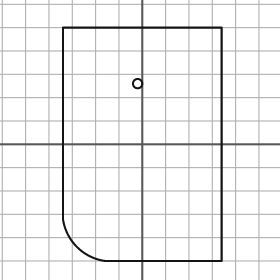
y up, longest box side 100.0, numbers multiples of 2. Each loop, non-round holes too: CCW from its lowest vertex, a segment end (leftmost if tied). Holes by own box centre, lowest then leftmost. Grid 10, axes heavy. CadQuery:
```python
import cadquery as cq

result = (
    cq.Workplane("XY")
    .moveTo(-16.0, -50.0)
    .lineTo(34.0, -50.0)
    .lineTo(34.0, 50.0)
    .lineTo(-34.0, 50.0)
    .lineTo(-34.0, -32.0)
    .threePointArc((-28.0, -44.0), (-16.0, -50.0))
    .close()
    .moveTo(-2.0, 26.0)
    .circle(2.0)
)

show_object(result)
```